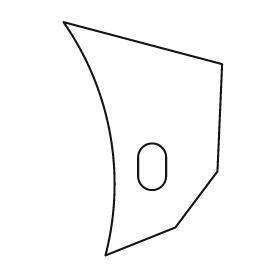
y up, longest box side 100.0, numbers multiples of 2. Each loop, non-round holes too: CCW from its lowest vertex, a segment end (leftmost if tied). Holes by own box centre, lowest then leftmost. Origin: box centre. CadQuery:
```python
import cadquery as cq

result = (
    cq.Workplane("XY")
    .moveTo(-16.0, -50.0)
    .lineTo(14.0, -38.0)
    .lineTo(32.0, -14.0)
    .lineTo(34.0, 32.0)
    .lineTo(-34.0, 50.0)
    .threePointArc((-14.0, 2.0), (-16.0, -50.0))
    .close()
    .moveTo(-2.0, -16.0)
    .threePointArc((4.0, -22.0), (10.0, -16.0))
    .lineTo(10.0, -8.0)
    .threePointArc((4.0, -2.0), (-2.0, -8.0))
    .close()
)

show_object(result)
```